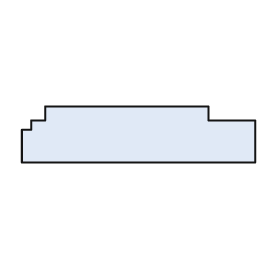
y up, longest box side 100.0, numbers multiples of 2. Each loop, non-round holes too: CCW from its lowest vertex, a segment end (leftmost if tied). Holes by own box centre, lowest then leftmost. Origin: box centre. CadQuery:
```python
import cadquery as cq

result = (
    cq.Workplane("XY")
    .moveTo(-50.0, -12.0)
    .lineTo(50.0, -12.0)
    .lineTo(50.0, 6.0)
    .lineTo(30.0, 6.0)
    .lineTo(30.0, 12.0)
    .lineTo(-40.0, 12.0)
    .lineTo(-40.0, 6.0)
    .lineTo(-46.0, 6.0)
    .lineTo(-46.0, 2.0)
    .lineTo(-50.0, 2.0)
    .close()
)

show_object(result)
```